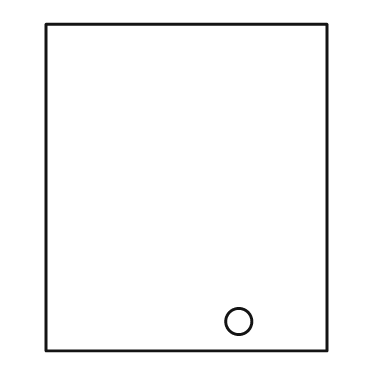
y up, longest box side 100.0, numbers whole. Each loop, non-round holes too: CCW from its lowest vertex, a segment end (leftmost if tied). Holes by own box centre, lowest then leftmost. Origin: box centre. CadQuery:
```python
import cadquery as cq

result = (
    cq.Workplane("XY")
    .moveTo(-43.0, -50.0)
    .lineTo(43.0, -50.0)
    .lineTo(43.0, 50.0)
    .lineTo(-43.0, 50.0)
    .close()
    .moveTo(16.0, -41.0)
    .circle(4.0)
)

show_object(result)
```